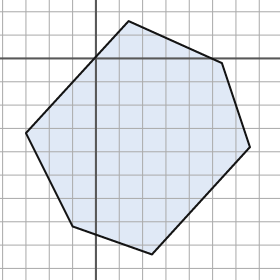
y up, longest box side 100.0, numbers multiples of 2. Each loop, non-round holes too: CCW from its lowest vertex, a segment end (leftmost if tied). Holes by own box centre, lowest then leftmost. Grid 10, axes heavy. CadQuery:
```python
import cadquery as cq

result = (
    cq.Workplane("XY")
    .moveTo(24.0, -84.0)
    .lineTo(66.0, -38.0)
    .lineTo(54.0, -2.0)
    .lineTo(14.0, 16.0)
    .lineTo(-30.0, -32.0)
    .lineTo(-10.0, -72.0)
    .close()
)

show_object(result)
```